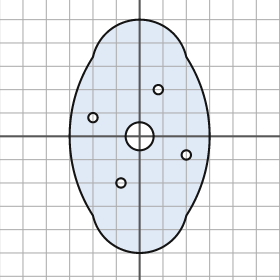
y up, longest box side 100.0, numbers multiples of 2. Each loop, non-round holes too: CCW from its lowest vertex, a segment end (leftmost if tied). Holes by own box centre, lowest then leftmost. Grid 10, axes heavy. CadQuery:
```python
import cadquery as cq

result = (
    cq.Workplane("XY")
    .moveTo(-20.0, -34.0)
    .threePointArc((0.0, -50.0), (20.0, -34.0))
    .threePointArc((30.0, 0.0), (20.0, 34.0))
    .threePointArc((0.0, 50.0), (-20.0, 34.0))
    .threePointArc((-30.0, 0.0), (-20.0, -34.0))
    .close()
    .moveTo(-8.0, -20.0)
    .circle(2.0)
    .moveTo(20.0, -8.0)
    .circle(2.0)
    .moveTo(0.0, 0.0)
    .circle(6.0)
    .moveTo(-20.0, 8.0)
    .circle(2.0)
    .moveTo(8.0, 20.0)
    .circle(2.0)
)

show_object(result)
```